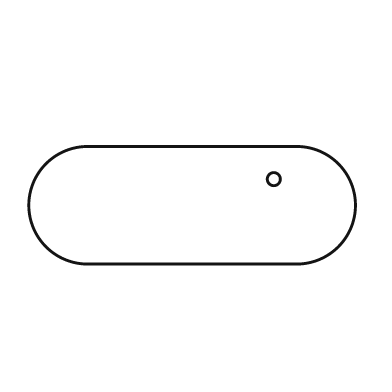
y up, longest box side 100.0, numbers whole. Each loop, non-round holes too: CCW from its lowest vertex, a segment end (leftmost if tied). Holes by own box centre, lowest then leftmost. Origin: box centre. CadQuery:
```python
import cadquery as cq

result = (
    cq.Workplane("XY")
    .moveTo(-32.0, -18.0)
    .lineTo(32.0, -18.0)
    .threePointArc((50.0, 0.0), (32.0, 18.0))
    .lineTo(-32.0, 18.0)
    .threePointArc((-50.0, 0.0), (-32.0, -18.0))
    .close()
    .moveTo(25.0, 8.0)
    .circle(2.0)
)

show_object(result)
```